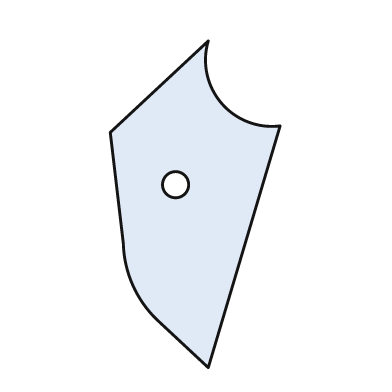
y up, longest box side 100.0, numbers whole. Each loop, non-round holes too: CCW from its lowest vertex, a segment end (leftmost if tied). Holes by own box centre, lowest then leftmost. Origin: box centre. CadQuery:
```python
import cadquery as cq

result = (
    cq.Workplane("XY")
    .moveTo(4.0, -50.0)
    .lineTo(26.0, 24.0)
    .threePointArc((8.0, 31.0), (4.0, 50.0))
    .lineTo(-26.0, 22.0)
    .lineTo(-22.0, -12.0)
    .threePointArc((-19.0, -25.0), (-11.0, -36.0))
    .close()
    .moveTo(-6.0, 6.0)
    .circle(4.0)
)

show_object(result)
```